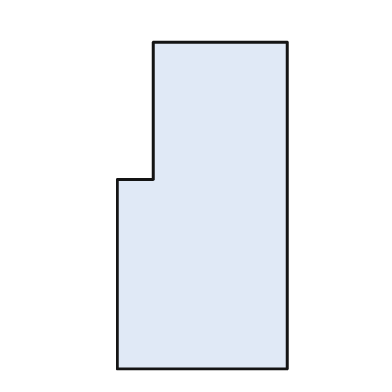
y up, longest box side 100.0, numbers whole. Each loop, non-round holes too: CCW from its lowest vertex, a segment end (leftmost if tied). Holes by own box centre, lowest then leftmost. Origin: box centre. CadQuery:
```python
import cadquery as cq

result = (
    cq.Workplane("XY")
    .moveTo(-26.0, -50.0)
    .lineTo(26.0, -50.0)
    .lineTo(26.0, 50.0)
    .lineTo(-15.0, 50.0)
    .lineTo(-15.0, 8.0)
    .lineTo(-26.0, 8.0)
    .close()
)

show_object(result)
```